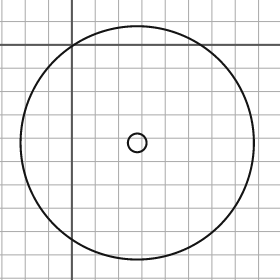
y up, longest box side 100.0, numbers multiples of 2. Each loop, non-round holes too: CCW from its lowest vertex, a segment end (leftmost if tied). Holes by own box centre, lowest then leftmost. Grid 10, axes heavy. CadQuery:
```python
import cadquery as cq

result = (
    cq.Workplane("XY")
    .moveTo(28.0, -42.0)
    .circle(50.0)
    .moveTo(28.0, -42.0)
    .circle(4.0)
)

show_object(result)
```